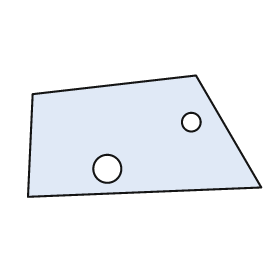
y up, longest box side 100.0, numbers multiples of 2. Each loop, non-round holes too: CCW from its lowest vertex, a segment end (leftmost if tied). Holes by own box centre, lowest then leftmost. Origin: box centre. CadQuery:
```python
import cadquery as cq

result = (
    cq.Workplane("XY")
    .moveTo(-50.0, -26.0)
    .lineTo(50.0, -22.0)
    .lineTo(22.0, 26.0)
    .lineTo(-48.0, 18.0)
    .close()
    .moveTo(-16.0, -14.0)
    .circle(6.0)
    .moveTo(20.0, 6.0)
    .circle(4.0)
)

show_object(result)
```